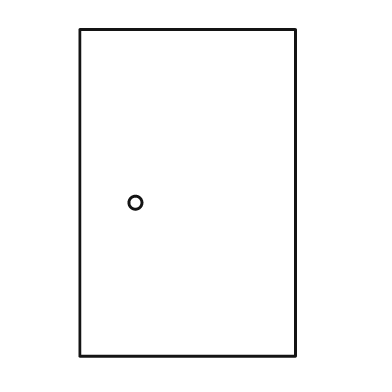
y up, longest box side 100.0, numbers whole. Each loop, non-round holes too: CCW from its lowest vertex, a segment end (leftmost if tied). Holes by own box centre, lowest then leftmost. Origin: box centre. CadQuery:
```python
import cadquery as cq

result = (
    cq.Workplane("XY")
    .moveTo(-33.0, -50.0)
    .lineTo(33.0, -50.0)
    .lineTo(33.0, 50.0)
    .lineTo(-33.0, 50.0)
    .close()
    .moveTo(-16.0, -3.0)
    .circle(2.0)
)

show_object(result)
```